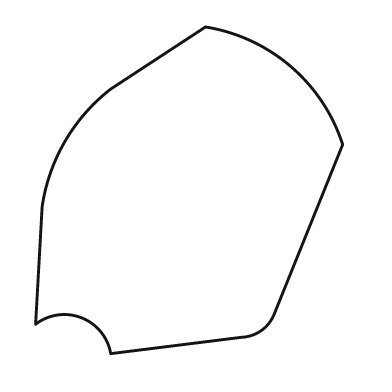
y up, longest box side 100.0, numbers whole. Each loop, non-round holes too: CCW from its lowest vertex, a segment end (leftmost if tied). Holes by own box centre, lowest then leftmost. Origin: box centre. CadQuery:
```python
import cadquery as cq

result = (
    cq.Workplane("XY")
    .moveTo(-24.0, -50.0)
    .lineTo(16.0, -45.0)
    .threePointArc((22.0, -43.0), (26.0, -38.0))
    .lineTo(47.0, 14.0)
    .threePointArc((31.0, 38.0), (5.0, 50.0))
    .lineTo(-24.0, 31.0)
    .threePointArc((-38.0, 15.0), (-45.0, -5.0))
    .lineTo(-47.0, -41.0)
    .threePointArc((-33.0, -39.0), (-24.0, -50.0))
    .close()
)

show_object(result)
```